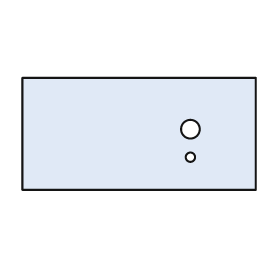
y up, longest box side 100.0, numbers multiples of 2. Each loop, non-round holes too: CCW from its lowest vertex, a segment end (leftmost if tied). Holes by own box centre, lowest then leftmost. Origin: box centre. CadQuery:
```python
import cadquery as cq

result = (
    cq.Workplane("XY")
    .moveTo(-50.0, -24.0)
    .lineTo(50.0, -24.0)
    .lineTo(50.0, 24.0)
    .lineTo(-50.0, 24.0)
    .close()
    .moveTo(22.0, -10.0)
    .circle(2.0)
    .moveTo(22.0, 2.0)
    .circle(4.0)
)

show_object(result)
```